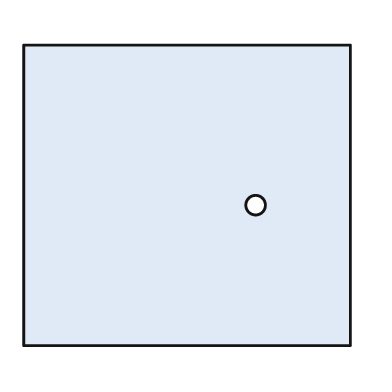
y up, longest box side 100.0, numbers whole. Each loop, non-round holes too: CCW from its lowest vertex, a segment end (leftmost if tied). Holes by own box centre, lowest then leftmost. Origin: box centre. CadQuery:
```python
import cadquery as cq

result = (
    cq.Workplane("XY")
    .moveTo(-50.0, -46.0)
    .lineTo(50.0, -46.0)
    .lineTo(50.0, 46.0)
    .lineTo(-50.0, 46.0)
    .close()
    .moveTo(21.0, -3.0)
    .circle(3.0)
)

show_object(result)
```